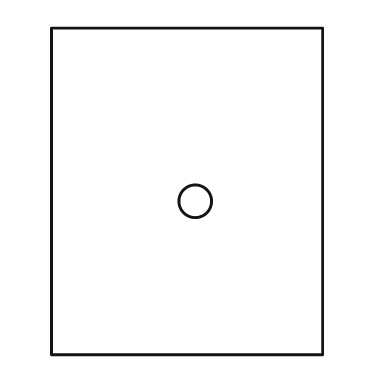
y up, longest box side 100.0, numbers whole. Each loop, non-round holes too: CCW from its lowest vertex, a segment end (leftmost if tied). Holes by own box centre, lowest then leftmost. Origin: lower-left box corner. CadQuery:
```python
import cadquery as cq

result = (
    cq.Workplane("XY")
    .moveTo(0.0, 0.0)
    .lineTo(83.0, 0.0)
    .lineTo(83.0, 100.0)
    .lineTo(0.0, 100.0)
    .close()
    .moveTo(44.0, 47.0)
    .circle(5.0)
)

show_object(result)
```